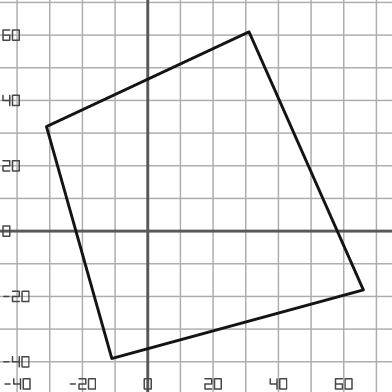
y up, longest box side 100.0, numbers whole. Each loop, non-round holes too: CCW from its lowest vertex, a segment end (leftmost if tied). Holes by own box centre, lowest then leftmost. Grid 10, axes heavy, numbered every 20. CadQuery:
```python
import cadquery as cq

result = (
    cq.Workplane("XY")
    .moveTo(-11.0, -39.0)
    .lineTo(66.0, -18.0)
    .lineTo(31.0, 61.0)
    .lineTo(-31.0, 32.0)
    .close()
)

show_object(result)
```